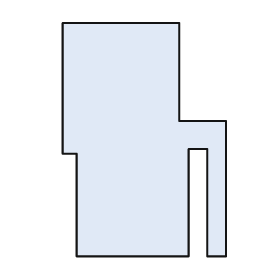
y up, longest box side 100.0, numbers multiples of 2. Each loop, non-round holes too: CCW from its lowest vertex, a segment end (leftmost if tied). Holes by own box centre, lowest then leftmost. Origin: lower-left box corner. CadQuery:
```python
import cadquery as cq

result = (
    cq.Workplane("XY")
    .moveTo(6.0, 0.0)
    .lineTo(54.0, 0.0)
    .lineTo(54.0, 46.0)
    .lineTo(62.0, 46.0)
    .lineTo(62.0, 0.0)
    .lineTo(70.0, 0.0)
    .lineTo(70.0, 58.0)
    .lineTo(50.0, 58.0)
    .lineTo(50.0, 100.0)
    .lineTo(0.0, 100.0)
    .lineTo(0.0, 44.0)
    .lineTo(6.0, 44.0)
    .close()
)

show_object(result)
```